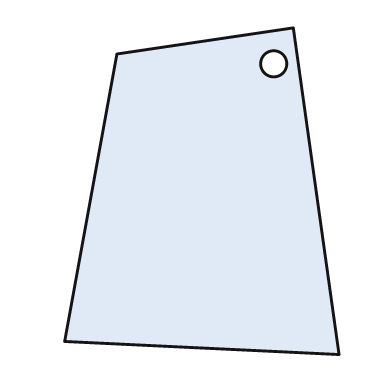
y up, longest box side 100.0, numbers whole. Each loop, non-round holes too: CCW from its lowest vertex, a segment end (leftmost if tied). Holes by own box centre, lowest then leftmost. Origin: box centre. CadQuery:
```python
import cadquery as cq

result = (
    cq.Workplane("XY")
    .moveTo(42.0, -50.0)
    .lineTo(28.0, 50.0)
    .lineTo(-26.0, 42.0)
    .lineTo(-42.0, -46.0)
    .close()
    .moveTo(22.0, 39.0)
    .circle(4.0)
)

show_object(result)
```